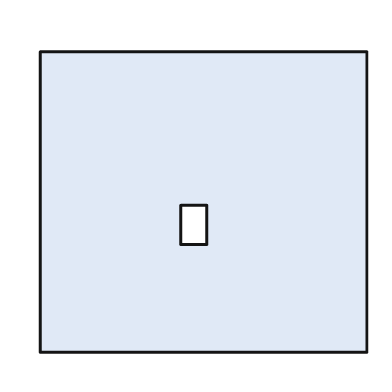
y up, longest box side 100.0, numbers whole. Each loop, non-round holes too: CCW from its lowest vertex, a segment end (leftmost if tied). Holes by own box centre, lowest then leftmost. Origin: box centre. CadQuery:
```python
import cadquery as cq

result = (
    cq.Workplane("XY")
    .moveTo(-50.0, -46.0)
    .lineTo(50.0, -46.0)
    .lineTo(50.0, 46.0)
    .lineTo(-50.0, 46.0)
    .close()
    .moveTo(-7.0, -13.0)
    .lineTo(1.0, -13.0)
    .lineTo(1.0, -1.0)
    .lineTo(-7.0, -1.0)
    .close()
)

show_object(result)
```